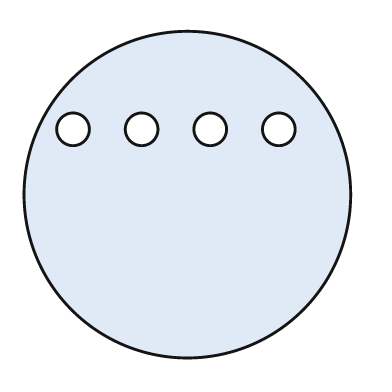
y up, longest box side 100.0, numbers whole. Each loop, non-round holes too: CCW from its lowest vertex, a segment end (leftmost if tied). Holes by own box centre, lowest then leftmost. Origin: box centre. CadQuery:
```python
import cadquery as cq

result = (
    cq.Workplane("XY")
    .moveTo(0.0, 0.0)
    .circle(50.0)
    .moveTo(-35.0, 20.0)
    .circle(5.0)
    .moveTo(-14.0, 20.0)
    .circle(5.0)
    .moveTo(7.0, 20.0)
    .circle(5.0)
    .moveTo(28.0, 20.0)
    .circle(5.0)
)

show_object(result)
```